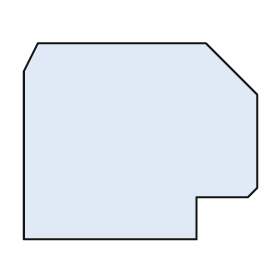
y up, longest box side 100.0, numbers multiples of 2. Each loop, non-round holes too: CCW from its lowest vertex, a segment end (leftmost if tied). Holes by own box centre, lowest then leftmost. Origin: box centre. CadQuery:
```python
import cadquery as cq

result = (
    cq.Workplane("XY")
    .moveTo(-50.0, -42.0)
    .lineTo(24.0, -42.0)
    .lineTo(24.0, -24.0)
    .lineTo(46.0, -24.0)
    .lineTo(50.0, -20.0)
    .lineTo(50.0, 20.0)
    .lineTo(28.0, 42.0)
    .lineTo(-44.0, 42.0)
    .lineTo(-50.0, 30.0)
    .close()
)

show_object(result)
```